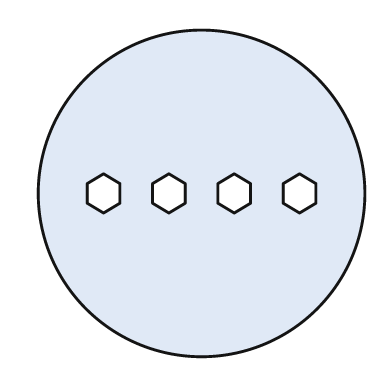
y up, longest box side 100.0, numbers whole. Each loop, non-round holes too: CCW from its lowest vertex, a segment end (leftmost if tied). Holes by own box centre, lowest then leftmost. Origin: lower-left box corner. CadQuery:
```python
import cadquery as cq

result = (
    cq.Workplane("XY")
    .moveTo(50.0, 50.0)
    .circle(50.0)
    .moveTo(20.0, 44.0)
    .lineTo(25.0, 47.0)
    .lineTo(25.0, 53.0)
    .lineTo(20.0, 56.0)
    .lineTo(15.0, 53.0)
    .lineTo(15.0, 47.0)
    .close()
    .moveTo(40.0, 44.0)
    .lineTo(45.0, 47.0)
    .lineTo(45.0, 53.0)
    .lineTo(40.0, 56.0)
    .lineTo(35.0, 53.0)
    .lineTo(35.0, 47.0)
    .close()
    .moveTo(60.0, 44.0)
    .lineTo(65.0, 47.0)
    .lineTo(65.0, 53.0)
    .lineTo(60.0, 56.0)
    .lineTo(55.0, 53.0)
    .lineTo(55.0, 47.0)
    .close()
    .moveTo(80.0, 44.0)
    .lineTo(85.0, 47.0)
    .lineTo(85.0, 53.0)
    .lineTo(80.0, 56.0)
    .lineTo(75.0, 53.0)
    .lineTo(75.0, 47.0)
    .close()
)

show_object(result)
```